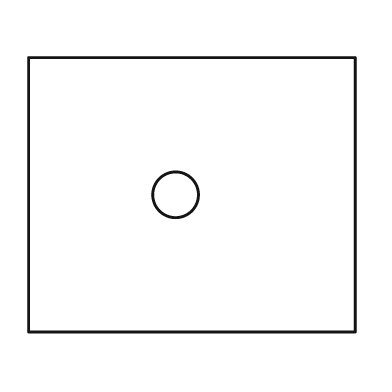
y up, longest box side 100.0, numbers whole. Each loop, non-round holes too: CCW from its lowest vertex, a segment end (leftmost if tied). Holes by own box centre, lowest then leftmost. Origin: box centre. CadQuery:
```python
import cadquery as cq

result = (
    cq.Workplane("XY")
    .moveTo(-50.0, -42.0)
    .lineTo(50.0, -42.0)
    .lineTo(50.0, 42.0)
    .lineTo(-50.0, 42.0)
    .close()
    .moveTo(-5.0, 0.0)
    .circle(7.0)
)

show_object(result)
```